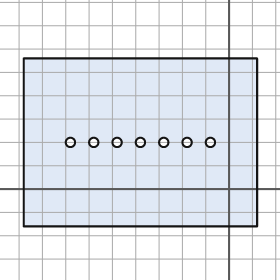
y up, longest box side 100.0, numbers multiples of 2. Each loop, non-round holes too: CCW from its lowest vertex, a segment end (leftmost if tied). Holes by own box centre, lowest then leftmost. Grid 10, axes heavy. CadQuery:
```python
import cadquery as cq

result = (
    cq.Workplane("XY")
    .moveTo(-88.0, -16.0)
    .lineTo(12.0, -16.0)
    .lineTo(12.0, 56.0)
    .lineTo(-88.0, 56.0)
    .close()
    .moveTo(-68.0, 20.0)
    .circle(2.0)
    .moveTo(-58.0, 20.0)
    .circle(2.0)
    .moveTo(-48.0, 20.0)
    .circle(2.0)
    .moveTo(-38.0, 20.0)
    .circle(2.0)
    .moveTo(-28.0, 20.0)
    .circle(2.0)
    .moveTo(-18.0, 20.0)
    .circle(2.0)
    .moveTo(-8.0, 20.0)
    .circle(2.0)
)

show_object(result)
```